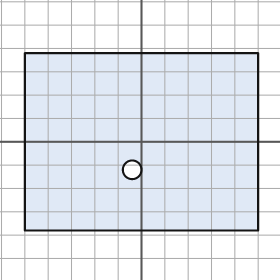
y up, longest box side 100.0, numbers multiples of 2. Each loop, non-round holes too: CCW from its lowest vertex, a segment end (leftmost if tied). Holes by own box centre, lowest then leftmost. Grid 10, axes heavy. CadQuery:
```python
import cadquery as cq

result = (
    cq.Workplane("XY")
    .moveTo(-50.0, -38.0)
    .lineTo(50.0, -38.0)
    .lineTo(50.0, 38.0)
    .lineTo(-50.0, 38.0)
    .close()
    .moveTo(-4.0, -12.0)
    .circle(4.0)
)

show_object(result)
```